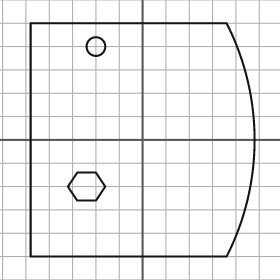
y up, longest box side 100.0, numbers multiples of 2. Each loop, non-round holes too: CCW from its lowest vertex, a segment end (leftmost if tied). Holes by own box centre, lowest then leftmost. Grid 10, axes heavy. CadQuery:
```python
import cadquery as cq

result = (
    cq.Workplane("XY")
    .moveTo(-48.0, -50.0)
    .lineTo(36.0, -50.0)
    .threePointArc((48.0, 0.0), (36.0, 50.0))
    .lineTo(-48.0, 50.0)
    .close()
    .moveTo(-28.0, -26.0)
    .lineTo(-20.0, -26.0)
    .lineTo(-16.0, -20.0)
    .lineTo(-20.0, -14.0)
    .lineTo(-28.0, -14.0)
    .lineTo(-32.0, -20.0)
    .close()
    .moveTo(-20.0, 40.0)
    .circle(4.0)
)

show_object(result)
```